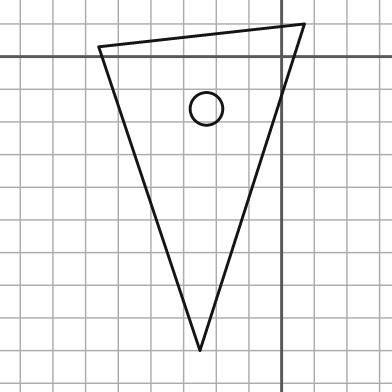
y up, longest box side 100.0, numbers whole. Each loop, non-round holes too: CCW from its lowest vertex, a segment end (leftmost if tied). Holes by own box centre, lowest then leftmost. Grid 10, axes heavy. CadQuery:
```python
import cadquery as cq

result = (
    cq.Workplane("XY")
    .moveTo(-25.0, -90.0)
    .lineTo(7.0, 10.0)
    .lineTo(-56.0, 3.0)
    .close()
    .moveTo(-23.0, -16.0)
    .circle(5.0)
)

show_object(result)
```